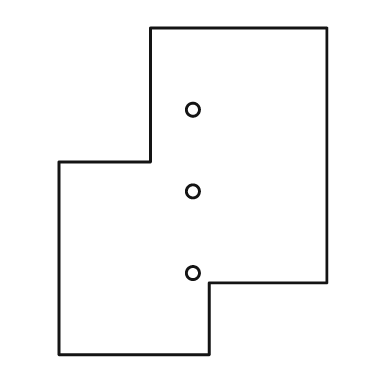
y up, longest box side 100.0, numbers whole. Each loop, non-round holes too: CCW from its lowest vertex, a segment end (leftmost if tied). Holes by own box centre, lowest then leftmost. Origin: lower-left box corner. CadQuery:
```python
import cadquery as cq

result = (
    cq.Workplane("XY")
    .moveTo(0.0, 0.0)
    .lineTo(46.0, 0.0)
    .lineTo(46.0, 22.0)
    .lineTo(82.0, 22.0)
    .lineTo(82.0, 100.0)
    .lineTo(28.0, 100.0)
    .lineTo(28.0, 59.0)
    .lineTo(0.0, 59.0)
    .close()
    .moveTo(41.0, 25.0)
    .circle(2.0)
    .moveTo(41.0, 50.0)
    .circle(2.0)
    .moveTo(41.0, 75.0)
    .circle(2.0)
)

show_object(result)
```